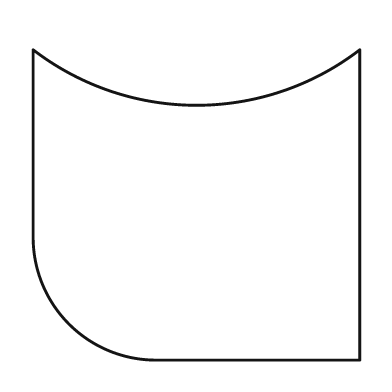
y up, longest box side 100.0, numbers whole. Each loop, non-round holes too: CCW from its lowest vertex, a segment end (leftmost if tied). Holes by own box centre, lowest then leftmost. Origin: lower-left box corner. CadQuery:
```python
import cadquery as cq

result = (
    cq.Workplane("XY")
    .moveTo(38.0, 0.0)
    .lineTo(100.0, 0.0)
    .lineTo(100.0, 95.0)
    .threePointArc((50.0, 78.0), (0.0, 95.0))
    .lineTo(0.0, 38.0)
    .threePointArc((11.0, 11.0), (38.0, 0.0))
    .close()
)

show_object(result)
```